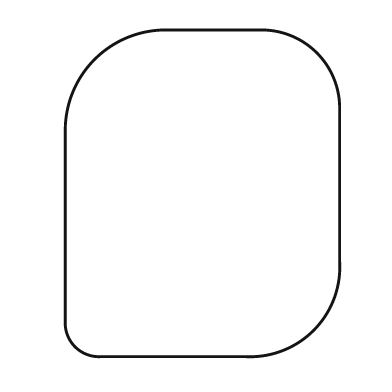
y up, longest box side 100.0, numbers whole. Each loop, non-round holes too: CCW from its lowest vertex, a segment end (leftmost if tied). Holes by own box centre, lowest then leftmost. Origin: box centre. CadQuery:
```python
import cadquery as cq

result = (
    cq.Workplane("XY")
    .moveTo(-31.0, -50.0)
    .lineTo(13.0, -50.0)
    .threePointArc((34.0, -42.0), (42.0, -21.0))
    .lineTo(42.0, 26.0)
    .threePointArc((35.0, 43.0), (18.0, 50.0))
    .lineTo(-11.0, 50.0)
    .threePointArc((-33.0, 41.0), (-42.0, 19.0))
    .lineTo(-42.0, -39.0)
    .threePointArc((-39.0, -47.0), (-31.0, -50.0))
    .close()
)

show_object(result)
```